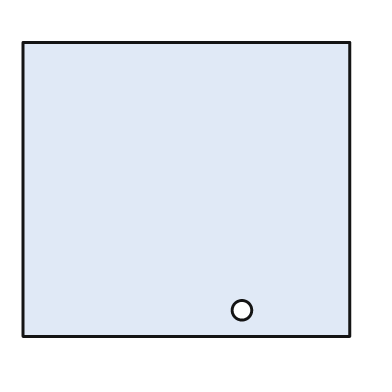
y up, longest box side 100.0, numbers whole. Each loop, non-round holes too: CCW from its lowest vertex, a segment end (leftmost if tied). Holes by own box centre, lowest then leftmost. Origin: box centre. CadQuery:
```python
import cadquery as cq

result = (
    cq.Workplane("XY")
    .moveTo(-50.0, -45.0)
    .lineTo(50.0, -45.0)
    .lineTo(50.0, 45.0)
    .lineTo(-50.0, 45.0)
    .close()
    .moveTo(17.0, -37.0)
    .circle(3.0)
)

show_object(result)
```